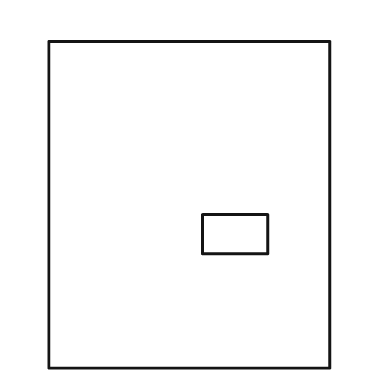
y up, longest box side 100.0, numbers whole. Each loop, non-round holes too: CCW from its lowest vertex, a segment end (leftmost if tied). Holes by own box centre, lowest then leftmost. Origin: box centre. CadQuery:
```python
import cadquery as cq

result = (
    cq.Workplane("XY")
    .moveTo(-43.0, -50.0)
    .lineTo(43.0, -50.0)
    .lineTo(43.0, 50.0)
    .lineTo(-43.0, 50.0)
    .close()
    .moveTo(4.0, -15.0)
    .lineTo(24.0, -15.0)
    .lineTo(24.0, -3.0)
    .lineTo(4.0, -3.0)
    .close()
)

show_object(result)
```